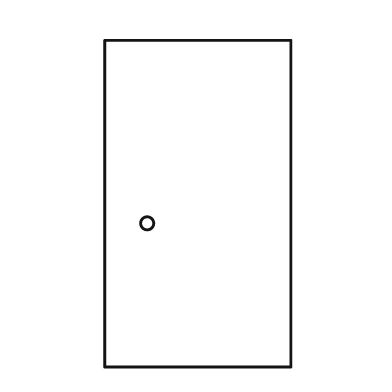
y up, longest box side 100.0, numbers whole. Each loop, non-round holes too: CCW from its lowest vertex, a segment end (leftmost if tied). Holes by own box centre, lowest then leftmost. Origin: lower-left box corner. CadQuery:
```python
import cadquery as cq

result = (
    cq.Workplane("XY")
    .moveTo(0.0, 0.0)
    .lineTo(57.0, 0.0)
    .lineTo(57.0, 100.0)
    .lineTo(0.0, 100.0)
    .close()
    .moveTo(13.0, 44.0)
    .circle(2.0)
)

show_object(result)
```